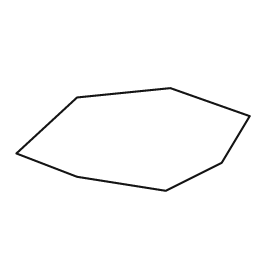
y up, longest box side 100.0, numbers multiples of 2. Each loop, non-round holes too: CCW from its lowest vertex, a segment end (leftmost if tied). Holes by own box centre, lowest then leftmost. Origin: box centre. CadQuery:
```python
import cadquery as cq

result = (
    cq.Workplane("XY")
    .moveTo(14.0, -22.0)
    .lineTo(38.0, -10.0)
    .lineTo(50.0, 10.0)
    .lineTo(16.0, 22.0)
    .lineTo(-24.0, 18.0)
    .lineTo(-50.0, -6.0)
    .lineTo(-24.0, -16.0)
    .close()
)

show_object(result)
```